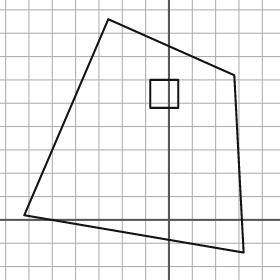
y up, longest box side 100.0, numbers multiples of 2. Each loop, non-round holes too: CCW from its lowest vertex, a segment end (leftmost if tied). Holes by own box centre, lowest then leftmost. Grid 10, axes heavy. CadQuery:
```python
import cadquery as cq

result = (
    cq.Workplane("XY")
    .moveTo(32.0, -14.0)
    .lineTo(28.0, 62.0)
    .lineTo(-26.0, 86.0)
    .lineTo(-62.0, 2.0)
    .close()
    .moveTo(-8.0, 48.0)
    .lineTo(4.0, 48.0)
    .lineTo(4.0, 60.0)
    .lineTo(-8.0, 60.0)
    .close()
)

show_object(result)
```